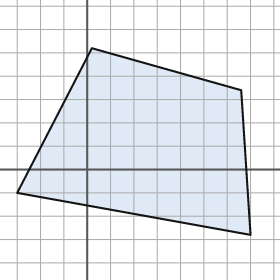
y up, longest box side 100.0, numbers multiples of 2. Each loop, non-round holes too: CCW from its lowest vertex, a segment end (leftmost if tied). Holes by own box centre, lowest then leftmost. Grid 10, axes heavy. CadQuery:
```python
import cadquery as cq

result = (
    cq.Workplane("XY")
    .moveTo(70.0, -28.0)
    .lineTo(66.0, 34.0)
    .lineTo(2.0, 52.0)
    .lineTo(-30.0, -10.0)
    .close()
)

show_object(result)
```